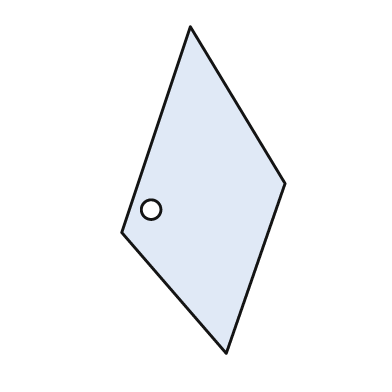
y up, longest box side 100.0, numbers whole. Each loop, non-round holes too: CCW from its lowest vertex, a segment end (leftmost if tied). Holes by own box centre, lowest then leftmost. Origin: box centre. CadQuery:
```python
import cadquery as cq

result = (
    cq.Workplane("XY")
    .moveTo(7.0, -50.0)
    .lineTo(25.0, 2.0)
    .lineTo(-4.0, 50.0)
    .lineTo(-25.0, -13.0)
    .close()
    .moveTo(-16.0, -6.0)
    .circle(3.0)
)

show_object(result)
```